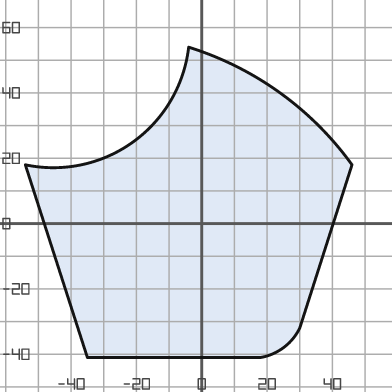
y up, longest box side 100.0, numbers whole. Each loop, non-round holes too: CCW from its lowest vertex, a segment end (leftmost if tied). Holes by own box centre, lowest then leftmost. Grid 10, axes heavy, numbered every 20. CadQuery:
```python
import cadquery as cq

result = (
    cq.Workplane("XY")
    .moveTo(-35.0, -41.0)
    .lineTo(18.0, -41.0)
    .threePointArc((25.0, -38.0), (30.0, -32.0))
    .lineTo(46.0, 18.0)
    .threePointArc((24.0, 40.0), (-4.0, 54.0))
    .threePointArc((-21.0, 25.0), (-54.0, 18.0))
    .close()
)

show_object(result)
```